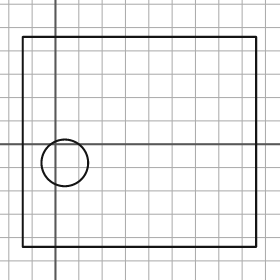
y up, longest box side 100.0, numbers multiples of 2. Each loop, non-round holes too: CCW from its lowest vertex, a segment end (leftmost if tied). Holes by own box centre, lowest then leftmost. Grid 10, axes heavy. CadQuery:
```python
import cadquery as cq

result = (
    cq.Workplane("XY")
    .moveTo(-14.0, -44.0)
    .lineTo(86.0, -44.0)
    .lineTo(86.0, 46.0)
    .lineTo(-14.0, 46.0)
    .close()
    .moveTo(4.0, -8.0)
    .circle(10.0)
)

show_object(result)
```